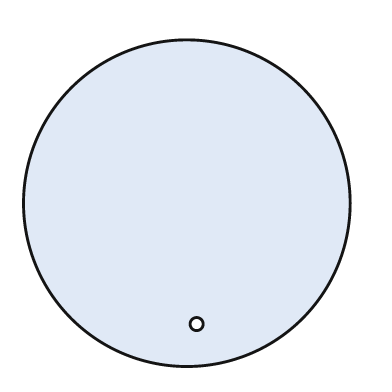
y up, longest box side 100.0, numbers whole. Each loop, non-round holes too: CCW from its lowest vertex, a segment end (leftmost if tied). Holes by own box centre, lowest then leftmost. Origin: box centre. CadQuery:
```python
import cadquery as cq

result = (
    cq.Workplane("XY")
    .moveTo(0.0, 0.0)
    .circle(50.0)
    .moveTo(3.0, -37.0)
    .circle(2.0)
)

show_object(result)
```